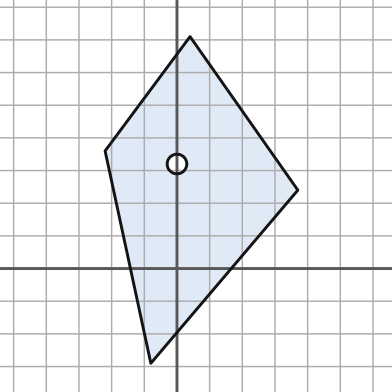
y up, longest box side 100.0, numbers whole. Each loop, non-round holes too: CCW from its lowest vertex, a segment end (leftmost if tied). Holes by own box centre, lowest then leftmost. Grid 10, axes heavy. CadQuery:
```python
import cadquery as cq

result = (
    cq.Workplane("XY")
    .moveTo(-8.0, -29.0)
    .lineTo(37.0, 24.0)
    .lineTo(4.0, 71.0)
    .lineTo(-22.0, 36.0)
    .close()
    .moveTo(0.0, 32.0)
    .circle(3.0)
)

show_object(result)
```